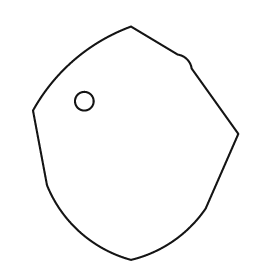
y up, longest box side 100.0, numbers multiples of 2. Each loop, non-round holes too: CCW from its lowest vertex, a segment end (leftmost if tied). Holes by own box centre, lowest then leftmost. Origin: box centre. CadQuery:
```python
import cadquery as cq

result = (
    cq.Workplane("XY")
    .moveTo(-2.0, -50.0)
    .threePointArc((16.0, -42.0), (30.0, -28.0))
    .lineTo(44.0, 4.0)
    .lineTo(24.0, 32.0)
    .threePointArc((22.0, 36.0), (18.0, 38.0))
    .lineTo(-2.0, 50.0)
    .threePointArc((-26.0, 36.0), (-44.0, 14.0))
    .lineTo(-38.0, -18.0)
    .threePointArc((-24.0, -38.0), (-2.0, -50.0))
    .close()
    .moveTo(-22.0, 18.0)
    .circle(4.0)
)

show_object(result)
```